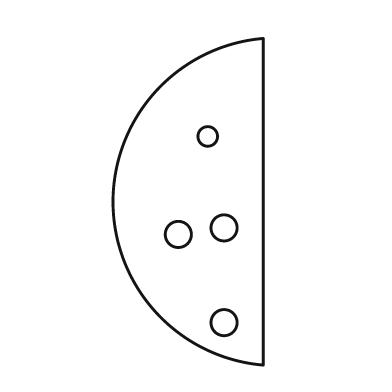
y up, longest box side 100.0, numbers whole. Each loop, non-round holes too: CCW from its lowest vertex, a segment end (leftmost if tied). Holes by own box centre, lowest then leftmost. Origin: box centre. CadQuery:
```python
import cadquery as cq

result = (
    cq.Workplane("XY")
    .moveTo(23.0, -50.0)
    .lineTo(23.0, 50.0)
    .threePointArc((-23.0, 0.0), (23.0, -50.0))
    .close()
    .moveTo(11.0, -37.0)
    .circle(4.0)
    .moveTo(-3.0, -10.0)
    .circle(4.0)
    .moveTo(11.0, -8.0)
    .circle(4.0)
    .moveTo(6.0, 20.0)
    .circle(3.0)
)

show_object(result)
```